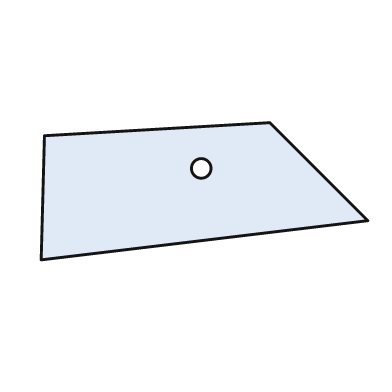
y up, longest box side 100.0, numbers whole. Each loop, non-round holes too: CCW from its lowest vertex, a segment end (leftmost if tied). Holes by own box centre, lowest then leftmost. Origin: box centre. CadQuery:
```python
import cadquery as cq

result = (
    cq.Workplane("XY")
    .moveTo(-50.0, -21.0)
    .lineTo(50.0, -9.0)
    .lineTo(20.0, 21.0)
    .lineTo(-49.0, 17.0)
    .close()
    .moveTo(-1.0, 7.0)
    .circle(3.0)
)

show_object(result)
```